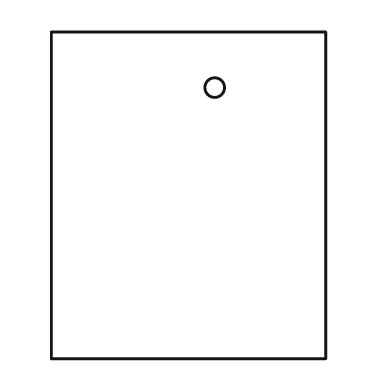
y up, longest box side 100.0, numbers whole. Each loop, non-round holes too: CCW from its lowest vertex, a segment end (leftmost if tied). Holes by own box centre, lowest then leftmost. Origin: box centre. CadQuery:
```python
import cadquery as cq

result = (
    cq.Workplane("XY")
    .moveTo(-42.0, -50.0)
    .lineTo(42.0, -50.0)
    .lineTo(42.0, 50.0)
    .lineTo(-42.0, 50.0)
    .close()
    .moveTo(8.0, 33.0)
    .circle(3.0)
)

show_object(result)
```